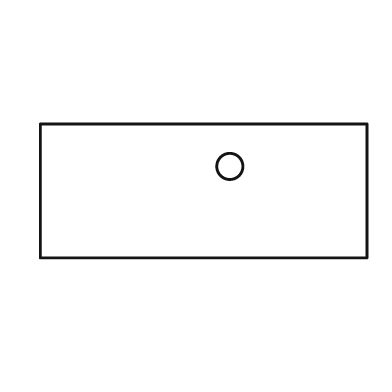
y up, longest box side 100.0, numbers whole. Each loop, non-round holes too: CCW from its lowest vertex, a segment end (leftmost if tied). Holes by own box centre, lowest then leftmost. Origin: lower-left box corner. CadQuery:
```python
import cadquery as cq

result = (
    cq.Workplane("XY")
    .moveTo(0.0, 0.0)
    .lineTo(100.0, 0.0)
    .lineTo(100.0, 41.0)
    .lineTo(0.0, 41.0)
    .close()
    .moveTo(58.0, 28.0)
    .circle(4.0)
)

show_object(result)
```